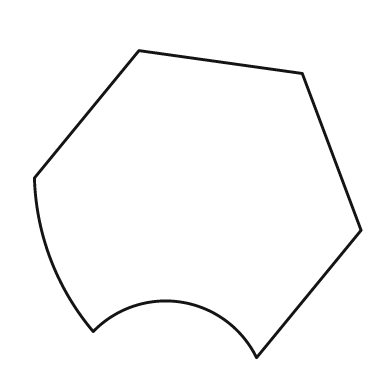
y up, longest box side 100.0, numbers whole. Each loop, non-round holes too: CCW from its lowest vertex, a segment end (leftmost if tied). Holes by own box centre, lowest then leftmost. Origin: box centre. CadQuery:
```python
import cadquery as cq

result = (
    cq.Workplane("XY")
    .moveTo(18.0, -47.0)
    .lineTo(50.0, -8.0)
    .lineTo(32.0, 40.0)
    .lineTo(-18.0, 47.0)
    .lineTo(-50.0, 8.0)
    .threePointArc((-45.0, -17.0), (-32.0, -39.0))
    .threePointArc((-5.0, -30.0), (18.0, -47.0))
    .close()
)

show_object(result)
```